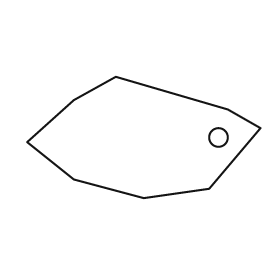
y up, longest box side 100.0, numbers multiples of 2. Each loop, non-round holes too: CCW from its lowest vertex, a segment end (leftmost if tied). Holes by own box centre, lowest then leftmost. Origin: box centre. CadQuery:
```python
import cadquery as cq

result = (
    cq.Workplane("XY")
    .moveTo(0.0, -26.0)
    .lineTo(28.0, -22.0)
    .lineTo(50.0, 4.0)
    .lineTo(36.0, 12.0)
    .lineTo(-12.0, 26.0)
    .lineTo(-30.0, 16.0)
    .lineTo(-50.0, -2.0)
    .lineTo(-30.0, -18.0)
    .close()
    .moveTo(32.0, 0.0)
    .circle(4.0)
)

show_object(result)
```